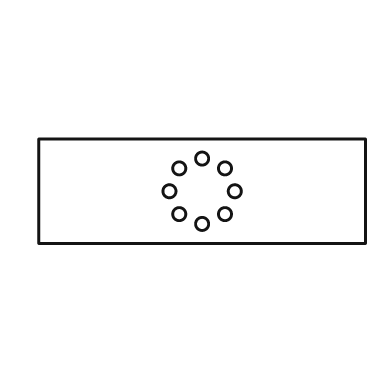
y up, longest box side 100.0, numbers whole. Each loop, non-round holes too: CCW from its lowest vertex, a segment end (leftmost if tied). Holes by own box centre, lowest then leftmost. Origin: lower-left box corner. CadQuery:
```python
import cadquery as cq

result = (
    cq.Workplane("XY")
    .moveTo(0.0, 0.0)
    .lineTo(100.0, 0.0)
    .lineTo(100.0, 32.0)
    .lineTo(0.0, 32.0)
    .close()
    .moveTo(50.0, 6.0)
    .circle(2.0)
    .moveTo(43.0, 9.0)
    .circle(2.0)
    .moveTo(57.0, 9.0)
    .circle(2.0)
    .moveTo(40.0, 16.0)
    .circle(2.0)
    .moveTo(60.0, 16.0)
    .circle(2.0)
    .moveTo(43.0, 23.0)
    .circle(2.0)
    .moveTo(57.0, 23.0)
    .circle(2.0)
    .moveTo(50.0, 26.0)
    .circle(2.0)
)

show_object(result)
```